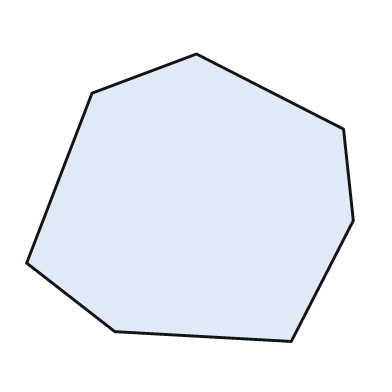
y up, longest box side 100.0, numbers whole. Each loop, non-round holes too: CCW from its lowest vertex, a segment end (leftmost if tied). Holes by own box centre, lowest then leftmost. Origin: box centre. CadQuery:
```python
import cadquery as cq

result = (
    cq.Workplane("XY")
    .moveTo(31.0, -44.0)
    .lineTo(50.0, -7.0)
    .lineTo(47.0, 21.0)
    .lineTo(2.0, 44.0)
    .lineTo(-30.0, 32.0)
    .lineTo(-50.0, -20.0)
    .lineTo(-23.0, -41.0)
    .close()
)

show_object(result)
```